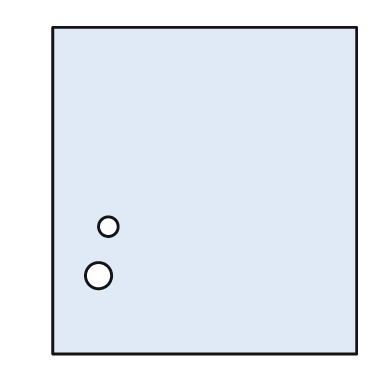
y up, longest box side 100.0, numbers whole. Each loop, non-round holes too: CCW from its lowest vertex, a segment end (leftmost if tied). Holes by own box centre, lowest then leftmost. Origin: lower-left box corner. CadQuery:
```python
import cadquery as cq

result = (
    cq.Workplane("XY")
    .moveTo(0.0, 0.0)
    .lineTo(93.0, 0.0)
    .lineTo(93.0, 100.0)
    .lineTo(0.0, 100.0)
    .close()
    .moveTo(14.0, 24.0)
    .circle(4.0)
    .moveTo(17.0, 39.0)
    .circle(3.0)
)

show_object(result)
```